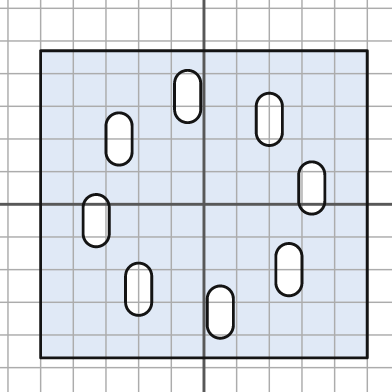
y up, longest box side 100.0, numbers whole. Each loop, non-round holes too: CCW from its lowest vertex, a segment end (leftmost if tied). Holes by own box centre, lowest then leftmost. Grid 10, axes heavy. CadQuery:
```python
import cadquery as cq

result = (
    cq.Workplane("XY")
    .moveTo(-50.0, -47.0)
    .lineTo(50.0, -47.0)
    .lineTo(50.0, 47.0)
    .lineTo(-50.0, 47.0)
    .close()
    .moveTo(1.0, -37.0)
    .threePointArc((5.0, -41.0), (9.0, -37.0))
    .lineTo(9.0, -29.0)
    .threePointArc((5.0, -25.0), (1.0, -29.0))
    .close()
    .moveTo(-24.0, -30.0)
    .threePointArc((-20.0, -34.0), (-16.0, -30.0))
    .lineTo(-16.0, -22.0)
    .threePointArc((-20.0, -18.0), (-24.0, -22.0))
    .close()
    .moveTo(22.0, -24.0)
    .threePointArc((26.0, -28.0), (30.0, -24.0))
    .lineTo(30.0, -16.0)
    .threePointArc((26.0, -12.0), (22.0, -16.0))
    .close()
    .moveTo(-37.0, -9.0)
    .threePointArc((-33.0, -13.0), (-29.0, -9.0))
    .lineTo(-29.0, -1.0)
    .threePointArc((-33.0, 3.0), (-37.0, -1.0))
    .close()
    .moveTo(29.0, 1.0)
    .threePointArc((33.0, -3.0), (37.0, 1.0))
    .lineTo(37.0, 9.0)
    .threePointArc((33.0, 13.0), (29.0, 9.0))
    .close()
    .moveTo(-30.0, 16.0)
    .threePointArc((-26.0, 12.0), (-22.0, 16.0))
    .lineTo(-22.0, 24.0)
    .threePointArc((-26.0, 28.0), (-30.0, 24.0))
    .close()
    .moveTo(16.0, 22.0)
    .threePointArc((20.0, 18.0), (24.0, 22.0))
    .lineTo(24.0, 30.0)
    .threePointArc((20.0, 34.0), (16.0, 30.0))
    .close()
    .moveTo(-9.0, 29.0)
    .threePointArc((-5.0, 25.0), (-1.0, 29.0))
    .lineTo(-1.0, 37.0)
    .threePointArc((-5.0, 41.0), (-9.0, 37.0))
    .close()
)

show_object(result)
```